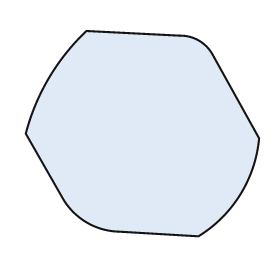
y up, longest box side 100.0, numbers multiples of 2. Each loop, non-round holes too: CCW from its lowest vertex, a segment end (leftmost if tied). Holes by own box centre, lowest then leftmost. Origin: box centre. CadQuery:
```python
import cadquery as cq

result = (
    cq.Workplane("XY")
    .moveTo(24.0, -44.0)
    .threePointArc((42.0, -26.0), (50.0, -2.0))
    .lineTo(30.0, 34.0)
    .threePointArc((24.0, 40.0), (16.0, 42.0))
    .lineTo(-24.0, 44.0)
    .threePointArc((-40.0, 24.0), (-50.0, 0.0))
    .lineTo(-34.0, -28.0)
    .threePointArc((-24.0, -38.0), (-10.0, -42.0))
    .close()
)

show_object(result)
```